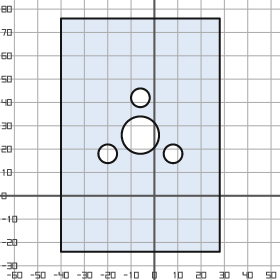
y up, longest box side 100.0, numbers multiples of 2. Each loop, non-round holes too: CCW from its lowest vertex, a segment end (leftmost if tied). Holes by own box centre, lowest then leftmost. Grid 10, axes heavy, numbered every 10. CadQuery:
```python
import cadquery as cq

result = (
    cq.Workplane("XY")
    .moveTo(-40.0, -24.0)
    .lineTo(28.0, -24.0)
    .lineTo(28.0, 76.0)
    .lineTo(-40.0, 76.0)
    .close()
    .moveTo(-20.0, 18.0)
    .circle(4.0)
    .moveTo(8.0, 18.0)
    .circle(4.0)
    .moveTo(-6.0, 26.0)
    .circle(8.0)
    .moveTo(-6.0, 42.0)
    .circle(4.0)
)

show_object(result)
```